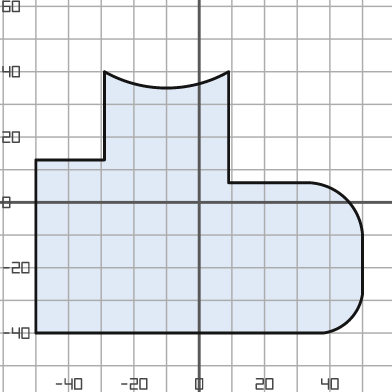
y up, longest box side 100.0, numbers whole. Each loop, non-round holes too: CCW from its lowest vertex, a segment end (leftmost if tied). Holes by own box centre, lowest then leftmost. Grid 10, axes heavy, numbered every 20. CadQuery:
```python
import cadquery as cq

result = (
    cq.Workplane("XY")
    .moveTo(-50.0, -40.0)
    .lineTo(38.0, -40.0)
    .threePointArc((46.0, -36.0), (50.0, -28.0))
    .lineTo(50.0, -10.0)
    .threePointArc((45.0, 1.0), (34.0, 6.0))
    .lineTo(9.0, 6.0)
    .lineTo(9.0, 40.0)
    .threePointArc((-10.0, 35.0), (-29.0, 40.0))
    .lineTo(-29.0, 13.0)
    .lineTo(-50.0, 13.0)
    .close()
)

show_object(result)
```